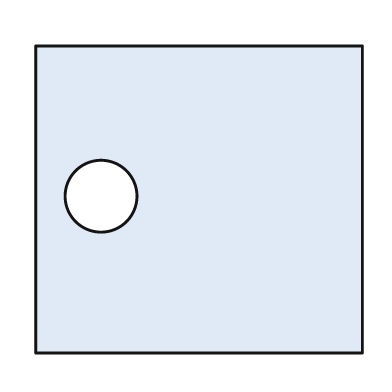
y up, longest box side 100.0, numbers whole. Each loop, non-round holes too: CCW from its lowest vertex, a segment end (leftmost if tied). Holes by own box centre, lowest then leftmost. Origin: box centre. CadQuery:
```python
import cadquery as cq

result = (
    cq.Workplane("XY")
    .moveTo(-50.0, -47.0)
    .lineTo(50.0, -47.0)
    .lineTo(50.0, 47.0)
    .lineTo(-50.0, 47.0)
    .close()
    .moveTo(-30.0, 1.0)
    .circle(11.0)
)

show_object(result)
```